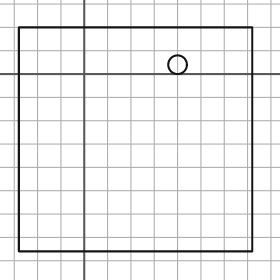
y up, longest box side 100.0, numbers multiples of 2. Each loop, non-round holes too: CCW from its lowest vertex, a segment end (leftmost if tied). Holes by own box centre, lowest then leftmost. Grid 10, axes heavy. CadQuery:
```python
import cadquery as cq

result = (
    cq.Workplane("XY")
    .moveTo(-28.0, -76.0)
    .lineTo(72.0, -76.0)
    .lineTo(72.0, 20.0)
    .lineTo(-28.0, 20.0)
    .close()
    .moveTo(40.0, 4.0)
    .circle(4.0)
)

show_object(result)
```